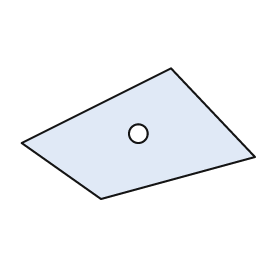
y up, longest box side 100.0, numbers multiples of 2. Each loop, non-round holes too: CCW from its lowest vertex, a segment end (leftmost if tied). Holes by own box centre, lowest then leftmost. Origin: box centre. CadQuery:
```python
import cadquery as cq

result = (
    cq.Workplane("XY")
    .moveTo(-16.0, -28.0)
    .lineTo(50.0, -10.0)
    .lineTo(14.0, 28.0)
    .lineTo(-50.0, -4.0)
    .close()
    .moveTo(0.0, 0.0)
    .circle(4.0)
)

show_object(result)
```